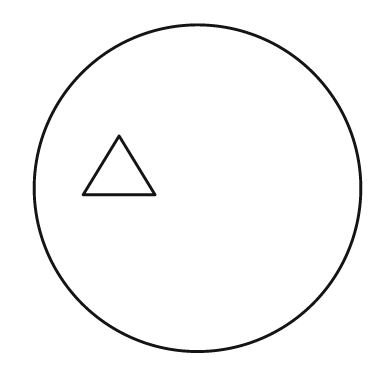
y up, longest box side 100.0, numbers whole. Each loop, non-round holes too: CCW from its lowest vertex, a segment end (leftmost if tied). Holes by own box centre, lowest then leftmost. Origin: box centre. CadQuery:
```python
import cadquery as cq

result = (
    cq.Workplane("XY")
    .moveTo(0.0, 0.0)
    .circle(50.0)
    .moveTo(-35.0, -2.0)
    .lineTo(-13.0, -2.0)
    .lineTo(-24.0, 16.0)
    .close()
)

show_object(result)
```